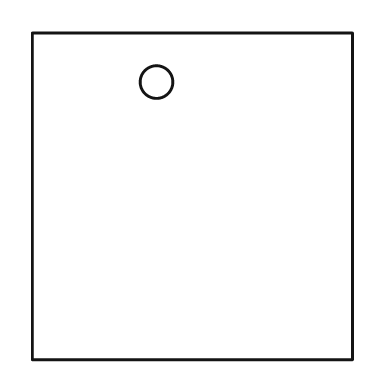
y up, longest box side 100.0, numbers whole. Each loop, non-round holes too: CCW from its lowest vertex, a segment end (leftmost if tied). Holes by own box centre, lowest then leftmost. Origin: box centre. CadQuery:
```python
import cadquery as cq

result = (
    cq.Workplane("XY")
    .moveTo(-49.0, -50.0)
    .lineTo(49.0, -50.0)
    .lineTo(49.0, 50.0)
    .lineTo(-49.0, 50.0)
    .close()
    .moveTo(-11.0, 35.0)
    .circle(5.0)
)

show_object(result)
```